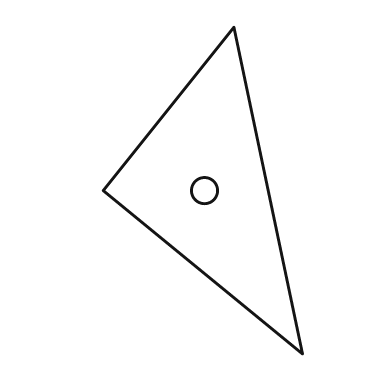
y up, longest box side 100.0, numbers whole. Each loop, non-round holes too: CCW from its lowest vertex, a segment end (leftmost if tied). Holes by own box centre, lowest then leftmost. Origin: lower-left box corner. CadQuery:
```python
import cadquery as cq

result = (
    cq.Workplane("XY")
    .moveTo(61.0, 0.0)
    .lineTo(40.0, 100.0)
    .lineTo(0.0, 50.0)
    .close()
    .moveTo(31.0, 50.0)
    .circle(4.0)
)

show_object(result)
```